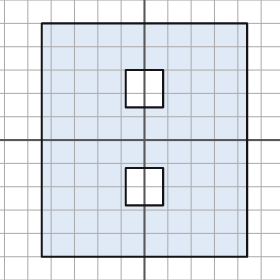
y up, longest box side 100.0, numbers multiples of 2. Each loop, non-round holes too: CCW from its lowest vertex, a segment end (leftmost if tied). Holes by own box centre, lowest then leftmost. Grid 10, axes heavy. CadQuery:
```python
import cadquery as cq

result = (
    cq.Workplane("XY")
    .moveTo(-44.0, -50.0)
    .lineTo(44.0, -50.0)
    .lineTo(44.0, 50.0)
    .lineTo(-44.0, 50.0)
    .close()
    .moveTo(-8.0, -28.0)
    .lineTo(8.0, -28.0)
    .lineTo(8.0, -12.0)
    .lineTo(-8.0, -12.0)
    .close()
    .moveTo(-8.0, 14.0)
    .lineTo(8.0, 14.0)
    .lineTo(8.0, 30.0)
    .lineTo(-8.0, 30.0)
    .close()
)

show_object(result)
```